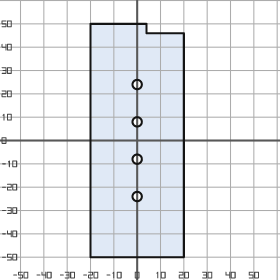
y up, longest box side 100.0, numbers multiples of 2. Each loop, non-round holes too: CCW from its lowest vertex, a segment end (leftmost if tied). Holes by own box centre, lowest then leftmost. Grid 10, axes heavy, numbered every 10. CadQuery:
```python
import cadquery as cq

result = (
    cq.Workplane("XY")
    .moveTo(-20.0, -50.0)
    .lineTo(20.0, -50.0)
    .lineTo(20.0, 46.0)
    .lineTo(4.0, 46.0)
    .lineTo(4.0, 50.0)
    .lineTo(-20.0, 50.0)
    .close()
    .moveTo(0.0, -24.0)
    .circle(2.0)
    .moveTo(0.0, -8.0)
    .circle(2.0)
    .moveTo(0.0, 8.0)
    .circle(2.0)
    .moveTo(0.0, 24.0)
    .circle(2.0)
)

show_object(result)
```